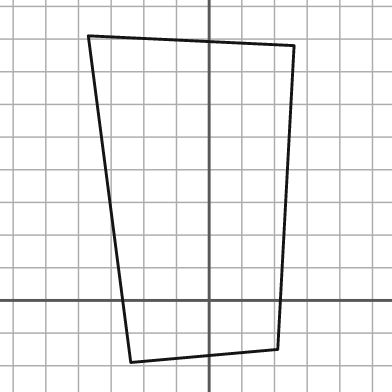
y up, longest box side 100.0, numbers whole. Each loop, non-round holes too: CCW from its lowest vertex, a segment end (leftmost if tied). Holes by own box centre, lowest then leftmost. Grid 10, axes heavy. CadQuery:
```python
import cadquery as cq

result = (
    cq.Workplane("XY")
    .moveTo(-24.0, -19.0)
    .lineTo(21.0, -15.0)
    .lineTo(26.0, 78.0)
    .lineTo(-37.0, 81.0)
    .close()
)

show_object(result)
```